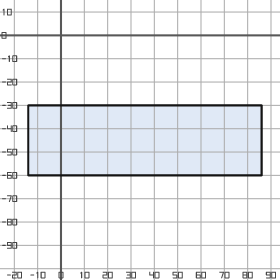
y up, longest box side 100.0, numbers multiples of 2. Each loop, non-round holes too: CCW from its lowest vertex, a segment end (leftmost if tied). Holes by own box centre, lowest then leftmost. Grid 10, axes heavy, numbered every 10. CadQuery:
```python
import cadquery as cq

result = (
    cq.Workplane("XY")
    .moveTo(-14.0, -60.0)
    .lineTo(86.0, -60.0)
    .lineTo(86.0, -30.0)
    .lineTo(-14.0, -30.0)
    .close()
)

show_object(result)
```